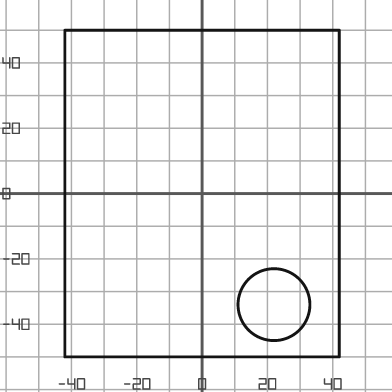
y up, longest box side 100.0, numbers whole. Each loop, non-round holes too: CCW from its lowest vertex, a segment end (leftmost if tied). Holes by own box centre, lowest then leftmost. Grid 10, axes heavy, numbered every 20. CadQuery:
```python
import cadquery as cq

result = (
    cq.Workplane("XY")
    .moveTo(-42.0, -50.0)
    .lineTo(42.0, -50.0)
    .lineTo(42.0, 50.0)
    .lineTo(-42.0, 50.0)
    .close()
    .moveTo(22.0, -34.0)
    .circle(11.0)
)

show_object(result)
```